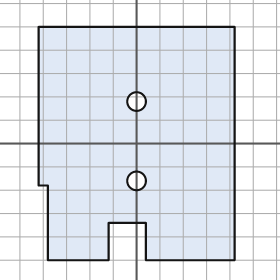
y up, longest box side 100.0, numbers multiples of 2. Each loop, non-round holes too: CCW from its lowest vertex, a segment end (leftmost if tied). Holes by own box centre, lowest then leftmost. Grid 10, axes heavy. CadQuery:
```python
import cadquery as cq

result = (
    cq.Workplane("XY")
    .moveTo(-38.0, -50.0)
    .lineTo(-12.0, -50.0)
    .lineTo(-12.0, -34.0)
    .lineTo(4.0, -34.0)
    .lineTo(4.0, -50.0)
    .lineTo(42.0, -50.0)
    .lineTo(42.0, 50.0)
    .lineTo(-42.0, 50.0)
    .lineTo(-42.0, -18.0)
    .lineTo(-38.0, -18.0)
    .close()
    .moveTo(0.0, -16.0)
    .circle(4.0)
    .moveTo(0.0, 18.0)
    .circle(4.0)
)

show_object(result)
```